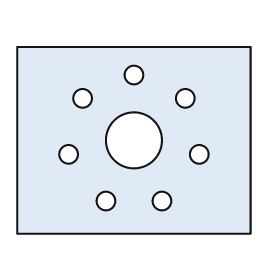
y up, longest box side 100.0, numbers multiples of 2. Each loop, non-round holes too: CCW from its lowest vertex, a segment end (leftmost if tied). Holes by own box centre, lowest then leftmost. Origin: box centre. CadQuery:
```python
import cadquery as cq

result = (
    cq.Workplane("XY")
    .moveTo(-50.0, -40.0)
    .lineTo(50.0, -40.0)
    .lineTo(50.0, 40.0)
    .lineTo(-50.0, 40.0)
    .close()
    .moveTo(-12.0, -26.0)
    .circle(4.0)
    .moveTo(12.0, -26.0)
    .circle(4.0)
    .moveTo(-28.0, -6.0)
    .circle(4.0)
    .moveTo(28.0, -6.0)
    .circle(4.0)
    .moveTo(0.0, 0.0)
    .circle(12.0)
    .moveTo(-22.0, 18.0)
    .circle(4.0)
    .moveTo(22.0, 18.0)
    .circle(4.0)
    .moveTo(0.0, 28.0)
    .circle(4.0)
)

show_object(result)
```